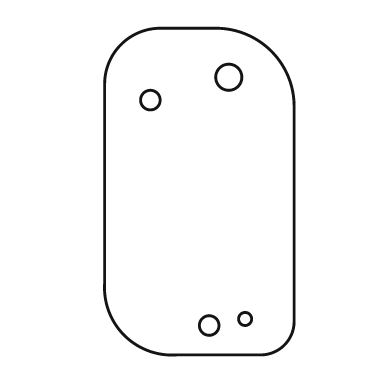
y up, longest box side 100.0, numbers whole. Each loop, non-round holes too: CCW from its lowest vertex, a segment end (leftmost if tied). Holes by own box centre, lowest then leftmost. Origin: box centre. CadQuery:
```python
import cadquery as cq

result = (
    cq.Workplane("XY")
    .moveTo(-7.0, -50.0)
    .lineTo(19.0, -50.0)
    .threePointArc((26.0, -47.0), (29.0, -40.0))
    .lineTo(29.0, 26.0)
    .threePointArc((22.0, 43.0), (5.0, 50.0))
    .lineTo(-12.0, 50.0)
    .threePointArc((-24.0, 45.0), (-29.0, 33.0))
    .lineTo(-29.0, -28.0)
    .threePointArc((-23.0, -44.0), (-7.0, -50.0))
    .close()
    .moveTo(3.0, -41.0)
    .circle(3.0)
    .moveTo(14.0, -39.0)
    .circle(2.0)
    .moveTo(-15.0, 28.0)
    .circle(3.0)
    .moveTo(9.0, 35.0)
    .circle(4.0)
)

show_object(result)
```